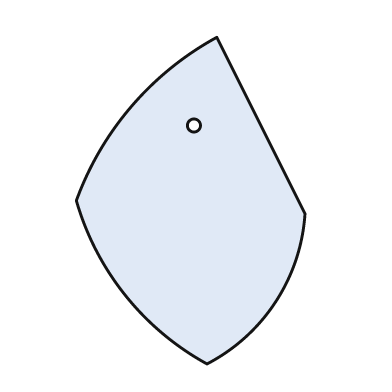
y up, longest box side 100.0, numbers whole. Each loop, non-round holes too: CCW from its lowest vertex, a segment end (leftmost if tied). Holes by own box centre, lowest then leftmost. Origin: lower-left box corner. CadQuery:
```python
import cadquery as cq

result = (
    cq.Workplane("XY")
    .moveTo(40.0, 0.0)
    .threePointArc((61.0, 19.0), (70.0, 46.0))
    .lineTo(43.0, 100.0)
    .threePointArc((17.0, 79.0), (0.0, 50.0))
    .threePointArc((15.0, 21.0), (40.0, 0.0))
    .close()
    .moveTo(36.0, 73.0)
    .circle(2.0)
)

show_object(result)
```